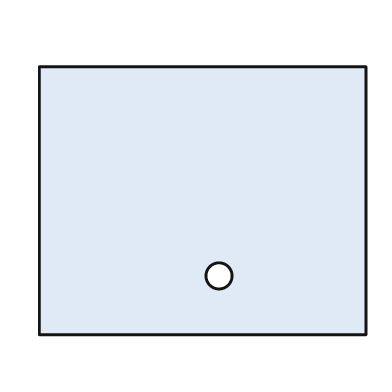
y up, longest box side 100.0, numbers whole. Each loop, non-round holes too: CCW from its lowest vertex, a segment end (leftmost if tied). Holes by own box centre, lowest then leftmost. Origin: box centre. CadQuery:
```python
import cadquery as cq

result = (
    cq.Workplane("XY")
    .moveTo(-50.0, -41.0)
    .lineTo(50.0, -41.0)
    .lineTo(50.0, 41.0)
    .lineTo(-50.0, 41.0)
    .close()
    .moveTo(5.0, -23.0)
    .circle(4.0)
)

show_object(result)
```